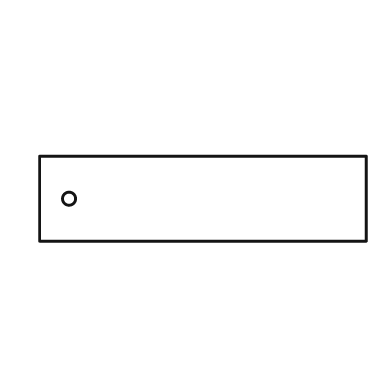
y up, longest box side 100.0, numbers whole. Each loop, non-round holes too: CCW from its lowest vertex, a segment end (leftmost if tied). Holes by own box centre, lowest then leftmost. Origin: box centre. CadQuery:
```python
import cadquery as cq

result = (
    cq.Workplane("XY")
    .moveTo(-50.0, -13.0)
    .lineTo(50.0, -13.0)
    .lineTo(50.0, 13.0)
    .lineTo(-50.0, 13.0)
    .close()
    .moveTo(-41.0, 0.0)
    .circle(2.0)
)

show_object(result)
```